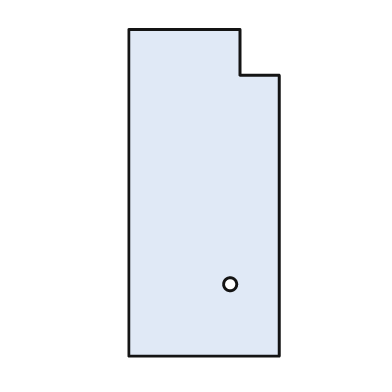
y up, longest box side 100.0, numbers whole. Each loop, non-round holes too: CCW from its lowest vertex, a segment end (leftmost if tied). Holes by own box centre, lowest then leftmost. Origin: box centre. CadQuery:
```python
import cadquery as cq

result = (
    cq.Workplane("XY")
    .moveTo(-23.0, -50.0)
    .lineTo(23.0, -50.0)
    .lineTo(23.0, 36.0)
    .lineTo(11.0, 36.0)
    .lineTo(11.0, 50.0)
    .lineTo(-23.0, 50.0)
    .close()
    .moveTo(8.0, -28.0)
    .circle(2.0)
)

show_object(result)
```